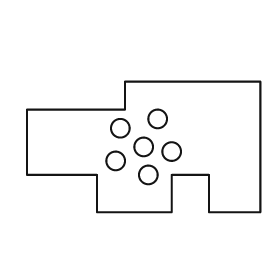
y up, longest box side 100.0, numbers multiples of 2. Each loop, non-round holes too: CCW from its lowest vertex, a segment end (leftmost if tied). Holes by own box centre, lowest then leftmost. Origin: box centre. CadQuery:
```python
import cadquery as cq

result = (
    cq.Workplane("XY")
    .moveTo(-20.0, -28.0)
    .lineTo(12.0, -28.0)
    .lineTo(12.0, -12.0)
    .lineTo(28.0, -12.0)
    .lineTo(28.0, -28.0)
    .lineTo(50.0, -28.0)
    .lineTo(50.0, 28.0)
    .lineTo(-8.0, 28.0)
    .lineTo(-8.0, 16.0)
    .lineTo(-50.0, 16.0)
    .lineTo(-50.0, -12.0)
    .lineTo(-20.0, -12.0)
    .close()
    .moveTo(2.0, -12.0)
    .circle(4.0)
    .moveTo(-12.0, -6.0)
    .circle(4.0)
    .moveTo(12.0, -2.0)
    .circle(4.0)
    .moveTo(0.0, 0.0)
    .circle(4.0)
    .moveTo(-10.0, 8.0)
    .circle(4.0)
    .moveTo(6.0, 12.0)
    .circle(4.0)
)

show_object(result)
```